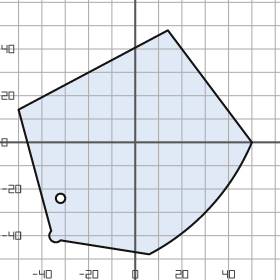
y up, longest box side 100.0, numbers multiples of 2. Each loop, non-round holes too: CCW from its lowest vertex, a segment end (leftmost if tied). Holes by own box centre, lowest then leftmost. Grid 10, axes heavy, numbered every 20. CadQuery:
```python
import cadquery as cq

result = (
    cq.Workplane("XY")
    .moveTo(6.0, -48.0)
    .threePointArc((32.0, -28.0), (50.0, 0.0))
    .lineTo(14.0, 48.0)
    .lineTo(-50.0, 14.0)
    .lineTo(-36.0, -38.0)
    .threePointArc((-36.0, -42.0), (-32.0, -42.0))
    .close()
    .moveTo(-32.0, -24.0)
    .circle(2.0)
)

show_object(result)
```